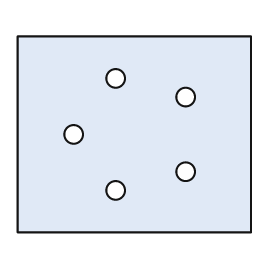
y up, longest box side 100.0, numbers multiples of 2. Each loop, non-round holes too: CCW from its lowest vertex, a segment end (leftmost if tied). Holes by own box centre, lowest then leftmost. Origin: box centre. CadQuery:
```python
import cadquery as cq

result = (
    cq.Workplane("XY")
    .moveTo(-50.0, -42.0)
    .lineTo(50.0, -42.0)
    .lineTo(50.0, 42.0)
    .lineTo(-50.0, 42.0)
    .close()
    .moveTo(-8.0, -24.0)
    .circle(4.0)
    .moveTo(22.0, -16.0)
    .circle(4.0)
    .moveTo(-26.0, 0.0)
    .circle(4.0)
    .moveTo(22.0, 16.0)
    .circle(4.0)
    .moveTo(-8.0, 24.0)
    .circle(4.0)
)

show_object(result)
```